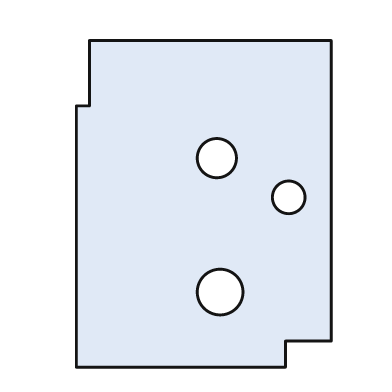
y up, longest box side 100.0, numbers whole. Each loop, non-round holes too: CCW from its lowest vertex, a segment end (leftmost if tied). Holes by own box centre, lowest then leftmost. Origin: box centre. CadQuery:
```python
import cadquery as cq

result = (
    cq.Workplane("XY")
    .moveTo(-39.0, -50.0)
    .lineTo(25.0, -50.0)
    .lineTo(25.0, -42.0)
    .lineTo(39.0, -42.0)
    .lineTo(39.0, 50.0)
    .lineTo(-35.0, 50.0)
    .lineTo(-35.0, 30.0)
    .lineTo(-39.0, 30.0)
    .close()
    .moveTo(5.0, -27.0)
    .circle(7.0)
    .moveTo(26.0, 2.0)
    .circle(5.0)
    .moveTo(4.0, 14.0)
    .circle(6.0)
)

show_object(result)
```